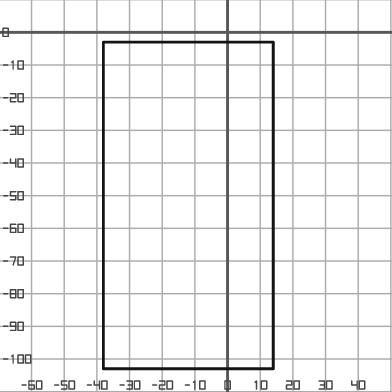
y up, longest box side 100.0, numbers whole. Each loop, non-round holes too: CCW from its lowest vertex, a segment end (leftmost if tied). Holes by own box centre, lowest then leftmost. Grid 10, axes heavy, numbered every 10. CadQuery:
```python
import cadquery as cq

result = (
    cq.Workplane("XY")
    .moveTo(-38.0, -103.0)
    .lineTo(14.0, -103.0)
    .lineTo(14.0, -3.0)
    .lineTo(-38.0, -3.0)
    .close()
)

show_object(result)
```